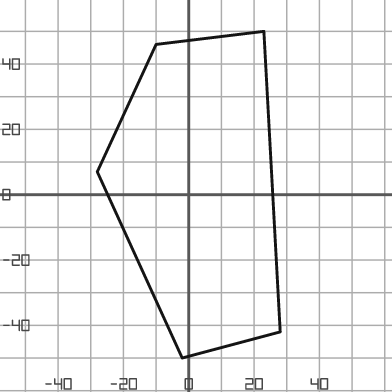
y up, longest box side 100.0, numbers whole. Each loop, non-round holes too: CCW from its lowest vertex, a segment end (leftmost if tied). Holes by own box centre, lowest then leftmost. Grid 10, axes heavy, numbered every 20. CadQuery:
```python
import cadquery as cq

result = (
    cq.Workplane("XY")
    .moveTo(-2.0, -50.0)
    .lineTo(28.0, -42.0)
    .lineTo(23.0, 50.0)
    .lineTo(-10.0, 46.0)
    .lineTo(-28.0, 7.0)
    .close()
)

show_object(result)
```